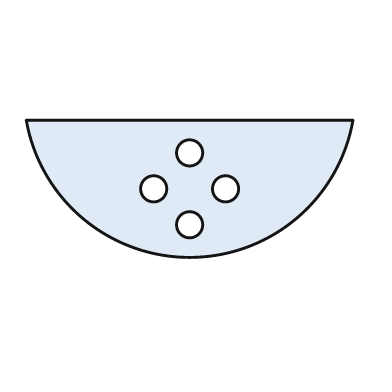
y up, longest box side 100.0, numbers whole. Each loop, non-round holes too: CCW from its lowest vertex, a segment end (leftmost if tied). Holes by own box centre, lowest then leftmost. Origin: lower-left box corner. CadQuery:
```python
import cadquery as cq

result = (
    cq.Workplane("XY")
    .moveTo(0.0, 42.0)
    .threePointArc((50.0, 0.0), (100.0, 42.0))
    .close()
    .moveTo(50.0, 10.0)
    .circle(4.0)
    .moveTo(39.0, 21.0)
    .circle(4.0)
    .moveTo(61.0, 21.0)
    .circle(4.0)
    .moveTo(50.0, 32.0)
    .circle(4.0)
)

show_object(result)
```